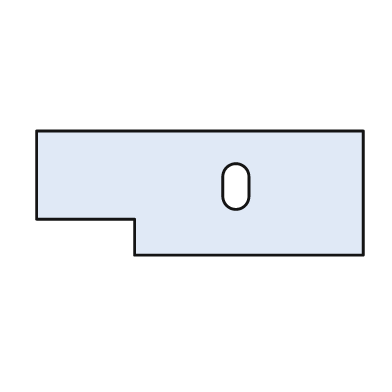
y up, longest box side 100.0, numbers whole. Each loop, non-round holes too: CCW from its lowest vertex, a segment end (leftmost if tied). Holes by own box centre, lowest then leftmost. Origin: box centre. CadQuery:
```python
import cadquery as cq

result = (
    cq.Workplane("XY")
    .moveTo(-20.0, -19.0)
    .lineTo(50.0, -19.0)
    .lineTo(50.0, 19.0)
    .lineTo(-50.0, 19.0)
    .lineTo(-50.0, -8.0)
    .lineTo(-20.0, -8.0)
    .close()
    .moveTo(7.0, -1.0)
    .threePointArc((11.0, -5.0), (15.0, -1.0))
    .lineTo(15.0, 5.0)
    .threePointArc((11.0, 9.0), (7.0, 5.0))
    .close()
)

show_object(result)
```